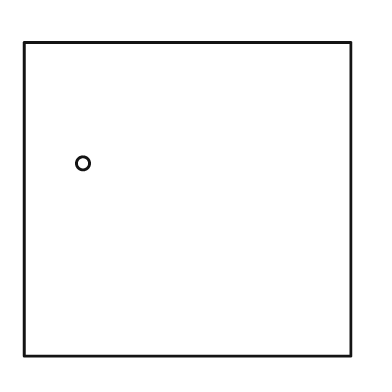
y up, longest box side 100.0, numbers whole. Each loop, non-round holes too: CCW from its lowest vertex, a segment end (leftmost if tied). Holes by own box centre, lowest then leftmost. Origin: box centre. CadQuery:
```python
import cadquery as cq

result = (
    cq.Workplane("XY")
    .moveTo(-50.0, -48.0)
    .lineTo(50.0, -48.0)
    .lineTo(50.0, 48.0)
    .lineTo(-50.0, 48.0)
    .close()
    .moveTo(-32.0, 11.0)
    .circle(2.0)
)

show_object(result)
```